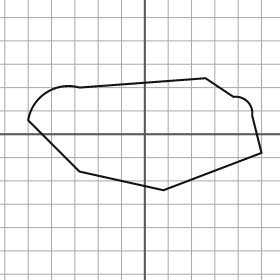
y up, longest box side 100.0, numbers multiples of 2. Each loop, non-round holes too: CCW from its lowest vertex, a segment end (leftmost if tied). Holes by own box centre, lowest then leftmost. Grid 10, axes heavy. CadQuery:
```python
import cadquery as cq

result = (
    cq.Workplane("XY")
    .moveTo(8.0, -24.0)
    .lineTo(50.0, -8.0)
    .lineTo(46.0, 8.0)
    .threePointArc((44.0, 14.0), (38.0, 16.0))
    .lineTo(26.0, 24.0)
    .lineTo(-28.0, 20.0)
    .threePointArc((-42.0, 18.0), (-50.0, 6.0))
    .lineTo(-28.0, -16.0)
    .close()
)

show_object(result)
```